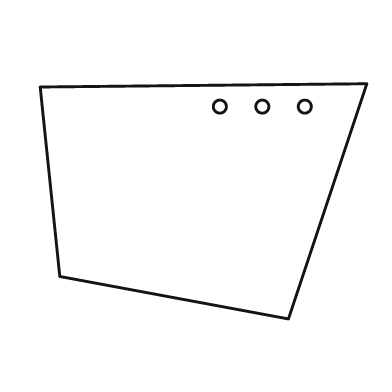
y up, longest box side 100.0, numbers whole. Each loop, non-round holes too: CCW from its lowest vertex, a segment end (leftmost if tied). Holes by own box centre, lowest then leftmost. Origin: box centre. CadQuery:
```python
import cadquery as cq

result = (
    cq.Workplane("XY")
    .moveTo(26.0, -36.0)
    .lineTo(50.0, 36.0)
    .lineTo(-50.0, 35.0)
    .lineTo(-44.0, -23.0)
    .close()
    .moveTo(5.0, 29.0)
    .circle(2.0)
    .moveTo(18.0, 29.0)
    .circle(2.0)
    .moveTo(31.0, 29.0)
    .circle(2.0)
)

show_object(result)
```